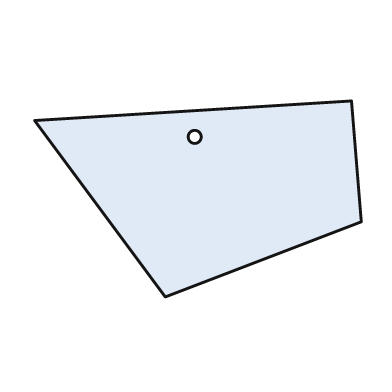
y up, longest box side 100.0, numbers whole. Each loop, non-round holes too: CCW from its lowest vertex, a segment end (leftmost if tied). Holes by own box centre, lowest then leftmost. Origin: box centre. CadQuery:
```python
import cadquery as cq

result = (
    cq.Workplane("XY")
    .moveTo(-10.0, -30.0)
    .lineTo(50.0, -7.0)
    .lineTo(47.0, 30.0)
    .lineTo(-50.0, 24.0)
    .close()
    .moveTo(-1.0, 19.0)
    .circle(2.0)
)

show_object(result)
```